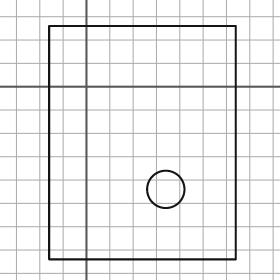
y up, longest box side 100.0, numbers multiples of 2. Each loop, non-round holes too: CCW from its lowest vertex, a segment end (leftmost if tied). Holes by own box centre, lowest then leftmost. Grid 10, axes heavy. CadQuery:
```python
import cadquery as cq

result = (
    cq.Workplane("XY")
    .moveTo(-16.0, -74.0)
    .lineTo(64.0, -74.0)
    .lineTo(64.0, 26.0)
    .lineTo(-16.0, 26.0)
    .close()
    .moveTo(34.0, -44.0)
    .circle(8.0)
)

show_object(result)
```